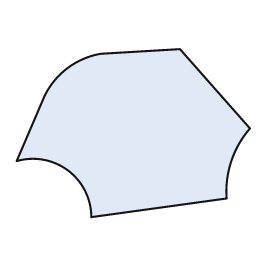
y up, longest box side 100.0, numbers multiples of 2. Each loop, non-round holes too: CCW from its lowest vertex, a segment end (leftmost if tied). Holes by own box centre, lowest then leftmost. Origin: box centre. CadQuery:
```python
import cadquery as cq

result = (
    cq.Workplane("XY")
    .moveTo(-18.0, -36.0)
    .lineTo(40.0, -28.0)
    .threePointArc((42.0, -12.0), (50.0, 2.0))
    .lineTo(20.0, 36.0)
    .lineTo(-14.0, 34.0)
    .threePointArc((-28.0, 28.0), (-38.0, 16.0))
    .lineTo(-50.0, -12.0)
    .threePointArc((-28.0, -16.0), (-18.0, -36.0))
    .close()
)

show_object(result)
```